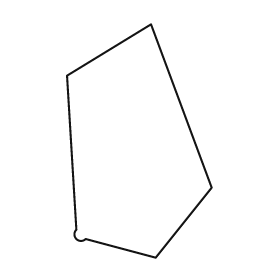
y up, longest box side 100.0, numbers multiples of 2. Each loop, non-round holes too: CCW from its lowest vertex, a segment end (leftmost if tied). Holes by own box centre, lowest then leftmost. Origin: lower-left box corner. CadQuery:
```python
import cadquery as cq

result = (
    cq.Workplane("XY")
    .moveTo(38.0, 0.0)
    .lineTo(62.0, 30.0)
    .lineTo(36.0, 100.0)
    .lineTo(0.0, 78.0)
    .lineTo(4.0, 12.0)
    .threePointArc((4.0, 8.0), (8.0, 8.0))
    .close()
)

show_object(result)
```